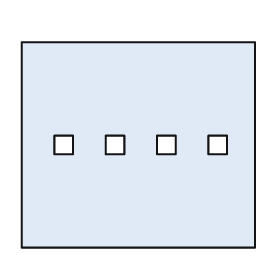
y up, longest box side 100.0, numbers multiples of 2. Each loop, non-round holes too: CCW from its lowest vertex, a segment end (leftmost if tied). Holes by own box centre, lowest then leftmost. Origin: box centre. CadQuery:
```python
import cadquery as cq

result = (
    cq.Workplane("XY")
    .moveTo(-50.0, -44.0)
    .lineTo(50.0, -44.0)
    .lineTo(50.0, 44.0)
    .lineTo(-50.0, 44.0)
    .close()
    .moveTo(-36.0, -4.0)
    .lineTo(-28.0, -4.0)
    .lineTo(-28.0, 4.0)
    .lineTo(-36.0, 4.0)
    .close()
    .moveTo(-14.0, -4.0)
    .lineTo(-6.0, -4.0)
    .lineTo(-6.0, 4.0)
    .lineTo(-14.0, 4.0)
    .close()
    .moveTo(8.0, -4.0)
    .lineTo(16.0, -4.0)
    .lineTo(16.0, 4.0)
    .lineTo(8.0, 4.0)
    .close()
    .moveTo(30.0, -4.0)
    .lineTo(38.0, -4.0)
    .lineTo(38.0, 4.0)
    .lineTo(30.0, 4.0)
    .close()
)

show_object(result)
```